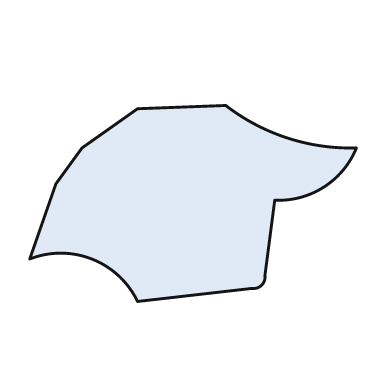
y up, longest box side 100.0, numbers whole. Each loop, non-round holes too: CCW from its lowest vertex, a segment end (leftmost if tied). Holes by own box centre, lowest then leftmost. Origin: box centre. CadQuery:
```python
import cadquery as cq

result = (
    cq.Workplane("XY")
    .moveTo(-17.0, -30.0)
    .lineTo(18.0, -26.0)
    .threePointArc((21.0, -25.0), (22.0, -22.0))
    .lineTo(25.0, 1.0)
    .threePointArc((40.0, 5.0), (50.0, 17.0))
    .threePointArc((29.0, 20.0), (10.0, 30.0))
    .lineTo(-17.0, 29.0)
    .lineTo(-34.0, 17.0)
    .lineTo(-42.0, 6.0)
    .lineTo(-50.0, -17.0)
    .threePointArc((-31.0, -17.0), (-17.0, -30.0))
    .close()
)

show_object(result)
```